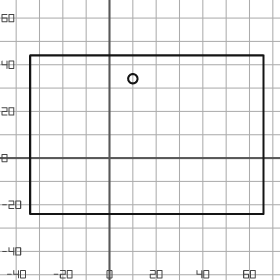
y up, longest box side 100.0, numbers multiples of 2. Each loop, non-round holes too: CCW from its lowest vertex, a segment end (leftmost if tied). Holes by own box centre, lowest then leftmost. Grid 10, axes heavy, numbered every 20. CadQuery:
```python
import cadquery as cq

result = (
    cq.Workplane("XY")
    .moveTo(-34.0, -24.0)
    .lineTo(66.0, -24.0)
    .lineTo(66.0, 44.0)
    .lineTo(-34.0, 44.0)
    .close()
    .moveTo(10.0, 34.0)
    .circle(2.0)
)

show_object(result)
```